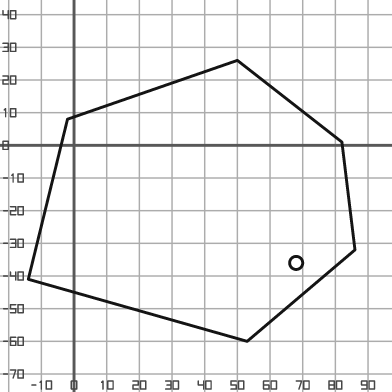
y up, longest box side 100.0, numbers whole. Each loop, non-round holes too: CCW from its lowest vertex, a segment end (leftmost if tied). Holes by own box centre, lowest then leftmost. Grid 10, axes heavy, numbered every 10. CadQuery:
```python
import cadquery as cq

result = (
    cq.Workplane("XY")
    .moveTo(53.0, -60.0)
    .lineTo(86.0, -32.0)
    .lineTo(82.0, 1.0)
    .lineTo(50.0, 26.0)
    .lineTo(-2.0, 8.0)
    .lineTo(-14.0, -41.0)
    .close()
    .moveTo(68.0, -36.0)
    .circle(2.0)
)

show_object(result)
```